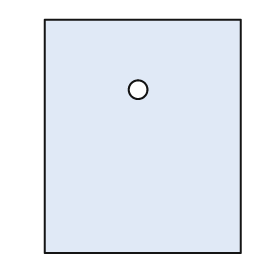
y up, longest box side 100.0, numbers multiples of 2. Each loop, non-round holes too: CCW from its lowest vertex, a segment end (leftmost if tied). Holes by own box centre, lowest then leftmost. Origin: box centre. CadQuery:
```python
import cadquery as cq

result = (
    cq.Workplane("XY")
    .moveTo(-42.0, -50.0)
    .lineTo(42.0, -50.0)
    .lineTo(42.0, 50.0)
    .lineTo(-42.0, 50.0)
    .close()
    .moveTo(-2.0, 20.0)
    .circle(4.0)
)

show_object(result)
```